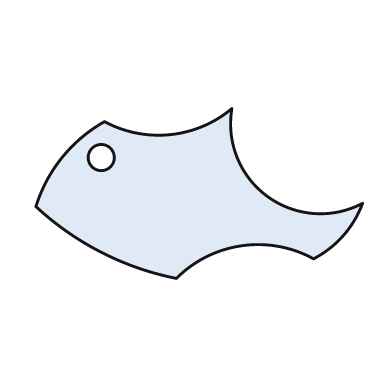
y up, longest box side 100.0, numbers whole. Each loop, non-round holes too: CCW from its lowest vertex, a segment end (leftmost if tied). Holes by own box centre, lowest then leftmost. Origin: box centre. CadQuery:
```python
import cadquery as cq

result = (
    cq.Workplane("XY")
    .moveTo(-7.0, -26.0)
    .threePointArc((13.0, -16.0), (35.0, -20.0))
    .threePointArc((44.0, -13.0), (50.0, -3.0))
    .threePointArc((21.0, -1.0), (10.0, 26.0))
    .threePointArc((-9.0, 18.0), (-29.0, 22.0))
    .threePointArc((-42.0, 11.0), (-50.0, -4.0))
    .threePointArc((-30.0, -18.0), (-7.0, -26.0))
    .close()
    .moveTo(-30.0, 11.0)
    .circle(4.0)
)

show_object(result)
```